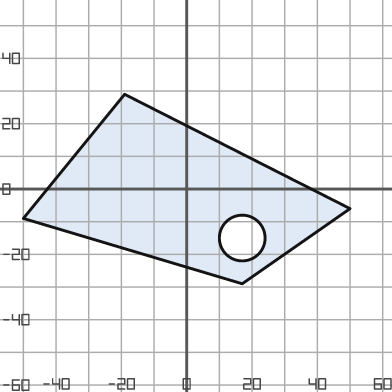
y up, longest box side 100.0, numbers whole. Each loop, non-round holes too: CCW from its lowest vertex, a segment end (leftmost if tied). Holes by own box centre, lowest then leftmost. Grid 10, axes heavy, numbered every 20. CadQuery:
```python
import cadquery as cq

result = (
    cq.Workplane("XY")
    .moveTo(17.0, -29.0)
    .lineTo(50.0, -6.0)
    .lineTo(-19.0, 29.0)
    .lineTo(-50.0, -9.0)
    .close()
    .moveTo(17.0, -15.0)
    .circle(7.0)
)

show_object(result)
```